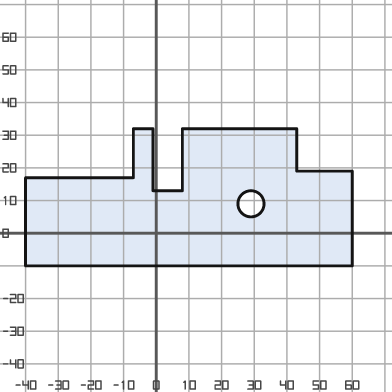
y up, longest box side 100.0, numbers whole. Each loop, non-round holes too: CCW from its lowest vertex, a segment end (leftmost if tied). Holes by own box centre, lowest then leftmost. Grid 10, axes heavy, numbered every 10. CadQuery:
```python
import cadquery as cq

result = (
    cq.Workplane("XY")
    .moveTo(-40.0, -10.0)
    .lineTo(60.0, -10.0)
    .lineTo(60.0, 19.0)
    .lineTo(43.0, 19.0)
    .lineTo(43.0, 32.0)
    .lineTo(8.0, 32.0)
    .lineTo(8.0, 13.0)
    .lineTo(-1.0, 13.0)
    .lineTo(-1.0, 32.0)
    .lineTo(-7.0, 32.0)
    .lineTo(-7.0, 17.0)
    .lineTo(-40.0, 17.0)
    .close()
    .moveTo(29.0, 9.0)
    .circle(4.0)
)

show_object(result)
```